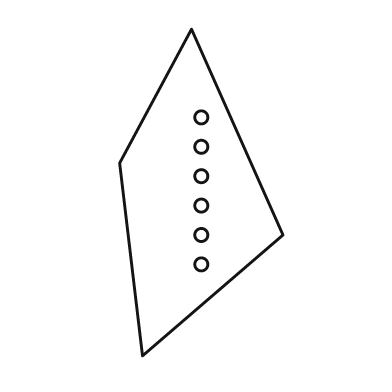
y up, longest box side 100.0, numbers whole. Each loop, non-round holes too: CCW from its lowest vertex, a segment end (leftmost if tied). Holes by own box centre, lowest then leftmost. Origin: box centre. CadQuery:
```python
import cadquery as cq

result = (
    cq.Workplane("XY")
    .moveTo(-18.0, -50.0)
    .lineTo(25.0, -13.0)
    .lineTo(-3.0, 50.0)
    .lineTo(-25.0, 9.0)
    .close()
    .moveTo(0.0, -22.0)
    .circle(2.0)
    .moveTo(0.0, -13.0)
    .circle(2.0)
    .moveTo(0.0, -4.0)
    .circle(2.0)
    .moveTo(0.0, 5.0)
    .circle(2.0)
    .moveTo(0.0, 14.0)
    .circle(2.0)
    .moveTo(0.0, 23.0)
    .circle(2.0)
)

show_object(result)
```